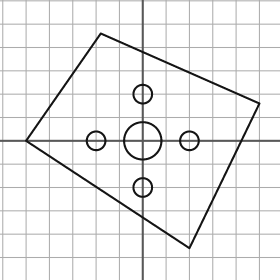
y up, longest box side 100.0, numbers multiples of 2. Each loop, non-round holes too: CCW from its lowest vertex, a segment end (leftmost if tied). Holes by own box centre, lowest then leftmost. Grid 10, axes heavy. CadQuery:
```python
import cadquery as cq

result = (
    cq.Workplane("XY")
    .moveTo(20.0, -46.0)
    .lineTo(50.0, 16.0)
    .lineTo(-18.0, 46.0)
    .lineTo(-50.0, 0.0)
    .close()
    .moveTo(0.0, -20.0)
    .circle(4.0)
    .moveTo(-20.0, 0.0)
    .circle(4.0)
    .moveTo(0.0, 0.0)
    .circle(8.0)
    .moveTo(20.0, 0.0)
    .circle(4.0)
    .moveTo(0.0, 20.0)
    .circle(4.0)
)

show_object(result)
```